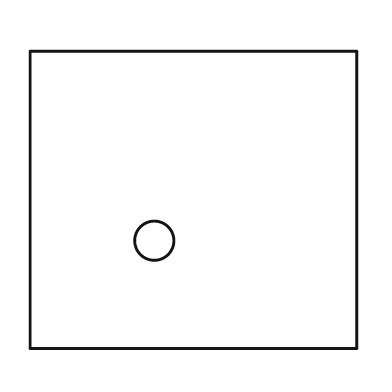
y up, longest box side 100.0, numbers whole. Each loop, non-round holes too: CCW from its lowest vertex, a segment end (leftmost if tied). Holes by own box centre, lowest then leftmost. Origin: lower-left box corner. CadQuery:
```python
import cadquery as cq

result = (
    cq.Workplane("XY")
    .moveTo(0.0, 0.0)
    .lineTo(100.0, 0.0)
    .lineTo(100.0, 91.0)
    .lineTo(0.0, 91.0)
    .close()
    .moveTo(38.0, 33.0)
    .circle(6.0)
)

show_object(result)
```